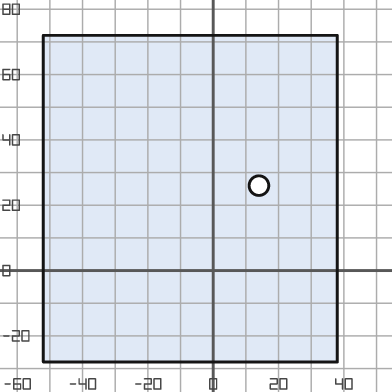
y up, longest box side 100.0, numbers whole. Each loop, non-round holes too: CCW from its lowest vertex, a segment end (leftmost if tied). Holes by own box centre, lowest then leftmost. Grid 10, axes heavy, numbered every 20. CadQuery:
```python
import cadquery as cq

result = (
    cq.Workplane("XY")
    .moveTo(-52.0, -28.0)
    .lineTo(38.0, -28.0)
    .lineTo(38.0, 72.0)
    .lineTo(-52.0, 72.0)
    .close()
    .moveTo(14.0, 26.0)
    .circle(3.0)
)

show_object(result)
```